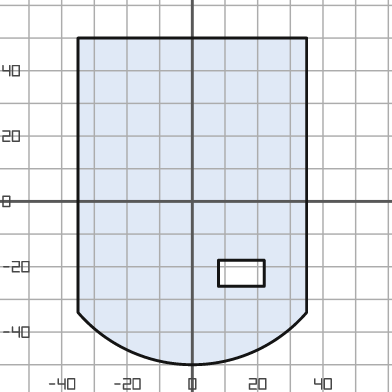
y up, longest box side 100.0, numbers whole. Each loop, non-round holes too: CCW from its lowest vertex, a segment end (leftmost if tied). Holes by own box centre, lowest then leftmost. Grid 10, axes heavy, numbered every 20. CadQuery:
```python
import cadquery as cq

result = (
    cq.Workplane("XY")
    .moveTo(-35.0, -34.0)
    .threePointArc((0.0, -50.0), (35.0, -34.0))
    .lineTo(35.0, 50.0)
    .lineTo(-35.0, 50.0)
    .close()
    .moveTo(8.0, -26.0)
    .lineTo(22.0, -26.0)
    .lineTo(22.0, -18.0)
    .lineTo(8.0, -18.0)
    .close()
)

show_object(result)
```